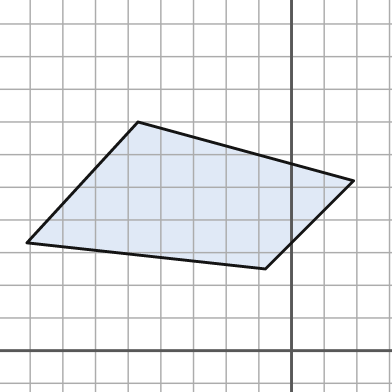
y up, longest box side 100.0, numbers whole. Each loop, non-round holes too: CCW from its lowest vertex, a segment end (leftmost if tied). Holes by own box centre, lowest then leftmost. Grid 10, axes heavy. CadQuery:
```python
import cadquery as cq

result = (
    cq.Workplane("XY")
    .moveTo(-8.0, 25.0)
    .lineTo(19.0, 52.0)
    .lineTo(-47.0, 70.0)
    .lineTo(-81.0, 33.0)
    .close()
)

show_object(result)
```